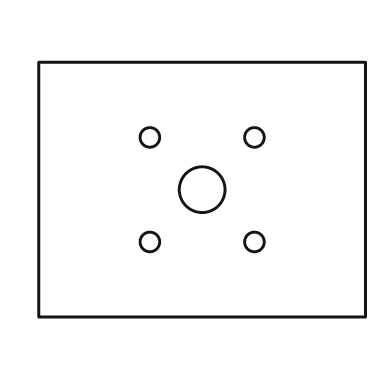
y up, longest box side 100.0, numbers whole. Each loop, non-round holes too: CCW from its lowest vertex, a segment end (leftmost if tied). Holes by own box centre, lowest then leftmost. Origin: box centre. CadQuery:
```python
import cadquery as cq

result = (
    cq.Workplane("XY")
    .moveTo(-50.0, -39.0)
    .lineTo(50.0, -39.0)
    .lineTo(50.0, 39.0)
    .lineTo(-50.0, 39.0)
    .close()
    .moveTo(-16.0, -16.0)
    .circle(3.0)
    .moveTo(16.0, -16.0)
    .circle(3.0)
    .moveTo(0.0, 0.0)
    .circle(7.0)
    .moveTo(-16.0, 16.0)
    .circle(3.0)
    .moveTo(16.0, 16.0)
    .circle(3.0)
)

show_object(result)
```